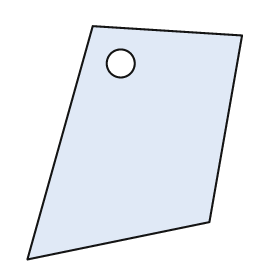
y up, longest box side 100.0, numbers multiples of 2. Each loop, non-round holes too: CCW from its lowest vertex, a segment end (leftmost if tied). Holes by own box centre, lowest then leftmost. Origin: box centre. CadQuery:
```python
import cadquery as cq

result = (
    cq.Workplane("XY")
    .moveTo(-46.0, -50.0)
    .lineTo(32.0, -34.0)
    .lineTo(46.0, 46.0)
    .lineTo(-18.0, 50.0)
    .close()
    .moveTo(-6.0, 34.0)
    .circle(6.0)
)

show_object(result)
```